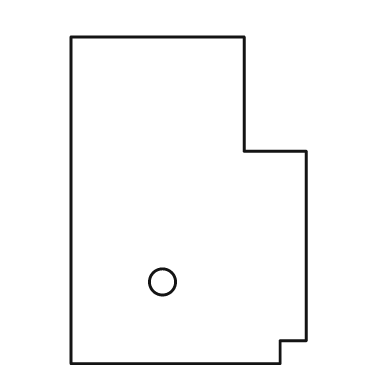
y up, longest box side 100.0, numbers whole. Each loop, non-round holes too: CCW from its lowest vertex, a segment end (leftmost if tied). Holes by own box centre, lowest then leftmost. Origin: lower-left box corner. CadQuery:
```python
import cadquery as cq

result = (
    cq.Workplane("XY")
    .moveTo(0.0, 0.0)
    .lineTo(64.0, 0.0)
    .lineTo(64.0, 7.0)
    .lineTo(72.0, 7.0)
    .lineTo(72.0, 65.0)
    .lineTo(53.0, 65.0)
    .lineTo(53.0, 100.0)
    .lineTo(0.0, 100.0)
    .close()
    .moveTo(28.0, 25.0)
    .circle(4.0)
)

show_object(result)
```